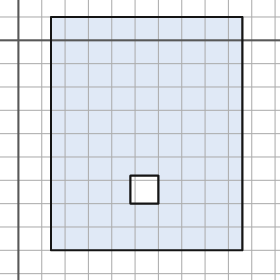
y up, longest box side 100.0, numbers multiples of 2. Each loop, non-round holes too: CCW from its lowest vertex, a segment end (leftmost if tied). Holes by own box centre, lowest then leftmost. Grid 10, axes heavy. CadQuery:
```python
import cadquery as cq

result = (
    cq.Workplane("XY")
    .moveTo(14.0, -90.0)
    .lineTo(96.0, -90.0)
    .lineTo(96.0, 10.0)
    .lineTo(14.0, 10.0)
    .close()
    .moveTo(48.0, -70.0)
    .lineTo(60.0, -70.0)
    .lineTo(60.0, -58.0)
    .lineTo(48.0, -58.0)
    .close()
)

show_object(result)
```